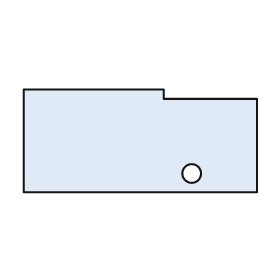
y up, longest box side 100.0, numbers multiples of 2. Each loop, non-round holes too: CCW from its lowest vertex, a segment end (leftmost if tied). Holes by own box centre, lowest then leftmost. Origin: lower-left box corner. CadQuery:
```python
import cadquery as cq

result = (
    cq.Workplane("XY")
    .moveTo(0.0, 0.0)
    .lineTo(100.0, 0.0)
    .lineTo(100.0, 40.0)
    .lineTo(60.0, 40.0)
    .lineTo(60.0, 44.0)
    .lineTo(0.0, 44.0)
    .close()
    .moveTo(72.0, 8.0)
    .circle(4.0)
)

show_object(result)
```